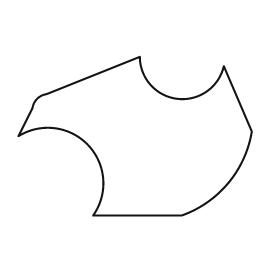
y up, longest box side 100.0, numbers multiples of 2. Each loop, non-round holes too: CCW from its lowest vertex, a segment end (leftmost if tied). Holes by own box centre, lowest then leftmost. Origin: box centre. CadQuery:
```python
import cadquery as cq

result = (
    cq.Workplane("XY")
    .moveTo(-18.0, -34.0)
    .lineTo(20.0, -34.0)
    .threePointArc((40.0, -20.0), (50.0, 2.0))
    .lineTo(38.0, 30.0)
    .threePointArc((18.0, 16.0), (2.0, 34.0))
    .lineTo(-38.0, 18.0)
    .threePointArc((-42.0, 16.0), (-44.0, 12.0))
    .lineTo(-50.0, 0.0)
    .threePointArc((-20.0, -4.0), (-18.0, -34.0))
    .close()
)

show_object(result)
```